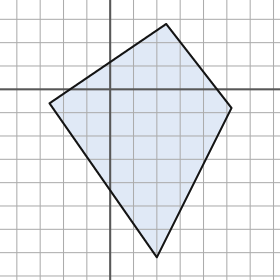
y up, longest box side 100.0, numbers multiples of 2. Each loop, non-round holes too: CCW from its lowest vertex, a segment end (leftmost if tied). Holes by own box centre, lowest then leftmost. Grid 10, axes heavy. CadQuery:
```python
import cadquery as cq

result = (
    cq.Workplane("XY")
    .moveTo(20.0, -72.0)
    .lineTo(52.0, -8.0)
    .lineTo(24.0, 28.0)
    .lineTo(-26.0, -6.0)
    .close()
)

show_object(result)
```